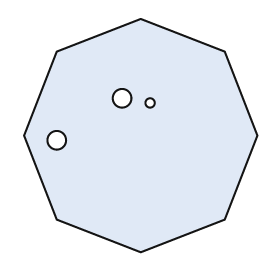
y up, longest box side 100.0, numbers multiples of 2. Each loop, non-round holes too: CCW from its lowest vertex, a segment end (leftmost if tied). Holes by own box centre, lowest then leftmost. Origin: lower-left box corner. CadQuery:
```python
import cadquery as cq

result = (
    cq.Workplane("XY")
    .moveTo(50.0, 0.0)
    .lineTo(86.0, 14.0)
    .lineTo(100.0, 50.0)
    .lineTo(86.0, 86.0)
    .lineTo(50.0, 100.0)
    .lineTo(14.0, 86.0)
    .lineTo(0.0, 50.0)
    .lineTo(14.0, 14.0)
    .close()
    .moveTo(14.0, 48.0)
    .circle(4.0)
    .moveTo(54.0, 64.0)
    .circle(2.0)
    .moveTo(42.0, 66.0)
    .circle(4.0)
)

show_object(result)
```